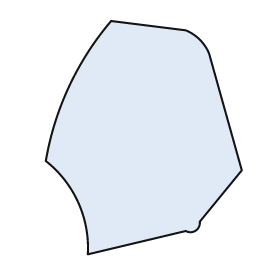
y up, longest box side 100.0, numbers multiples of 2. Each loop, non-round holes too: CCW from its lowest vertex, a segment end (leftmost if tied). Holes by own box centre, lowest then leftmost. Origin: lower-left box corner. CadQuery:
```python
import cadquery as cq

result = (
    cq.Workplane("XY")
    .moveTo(18.0, 0.0)
    .lineTo(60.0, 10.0)
    .threePointArc((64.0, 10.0), (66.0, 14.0))
    .lineTo(84.0, 36.0)
    .lineTo(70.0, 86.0)
    .threePointArc((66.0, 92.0), (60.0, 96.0))
    .lineTo(28.0, 100.0)
    .threePointArc((10.0, 72.0), (0.0, 40.0))
    .threePointArc((14.0, 22.0), (18.0, 0.0))
    .close()
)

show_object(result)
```